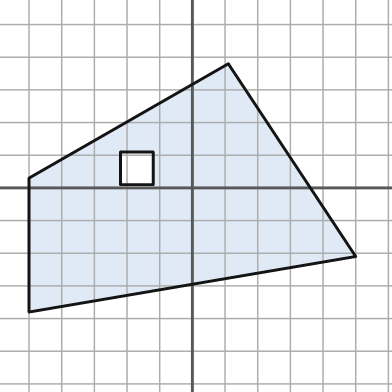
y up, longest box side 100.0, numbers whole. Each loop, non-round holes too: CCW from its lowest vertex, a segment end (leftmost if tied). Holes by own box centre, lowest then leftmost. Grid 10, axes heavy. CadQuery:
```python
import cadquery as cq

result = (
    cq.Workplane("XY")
    .moveTo(-50.0, -38.0)
    .lineTo(50.0, -21.0)
    .lineTo(11.0, 38.0)
    .lineTo(-50.0, 3.0)
    .close()
    .moveTo(-22.0, 1.0)
    .lineTo(-12.0, 1.0)
    .lineTo(-12.0, 11.0)
    .lineTo(-22.0, 11.0)
    .close()
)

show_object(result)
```